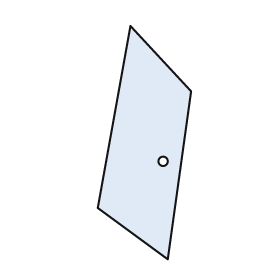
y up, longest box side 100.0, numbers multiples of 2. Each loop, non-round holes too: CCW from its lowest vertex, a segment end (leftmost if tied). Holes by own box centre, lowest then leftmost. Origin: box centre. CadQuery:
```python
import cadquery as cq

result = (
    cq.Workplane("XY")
    .moveTo(10.0, -50.0)
    .lineTo(20.0, 22.0)
    .lineTo(-6.0, 50.0)
    .lineTo(-20.0, -28.0)
    .close()
    .moveTo(8.0, -8.0)
    .circle(2.0)
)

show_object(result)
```